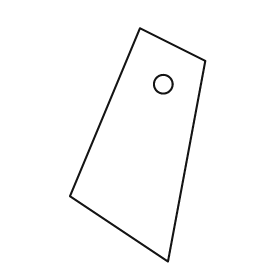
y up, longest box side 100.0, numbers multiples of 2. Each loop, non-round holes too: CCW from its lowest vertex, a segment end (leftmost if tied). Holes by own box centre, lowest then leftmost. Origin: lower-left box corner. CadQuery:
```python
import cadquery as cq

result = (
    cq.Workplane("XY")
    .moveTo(42.0, 0.0)
    .lineTo(58.0, 86.0)
    .lineTo(30.0, 100.0)
    .lineTo(0.0, 28.0)
    .close()
    .moveTo(40.0, 76.0)
    .circle(4.0)
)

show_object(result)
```